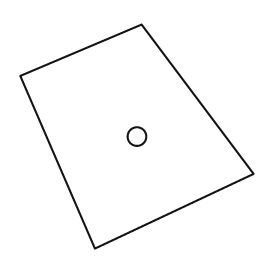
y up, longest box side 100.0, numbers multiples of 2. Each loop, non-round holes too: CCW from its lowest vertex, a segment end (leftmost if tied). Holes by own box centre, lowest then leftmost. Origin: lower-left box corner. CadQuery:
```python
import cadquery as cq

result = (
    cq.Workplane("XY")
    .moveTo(32.0, 0.0)
    .lineTo(100.0, 32.0)
    .lineTo(52.0, 96.0)
    .lineTo(0.0, 74.0)
    .close()
    .moveTo(50.0, 48.0)
    .circle(4.0)
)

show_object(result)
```